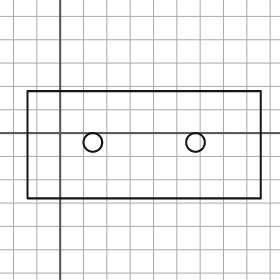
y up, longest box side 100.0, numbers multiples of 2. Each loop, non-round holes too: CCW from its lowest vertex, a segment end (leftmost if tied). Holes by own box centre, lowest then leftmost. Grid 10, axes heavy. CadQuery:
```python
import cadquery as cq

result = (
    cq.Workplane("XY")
    .moveTo(-14.0, -28.0)
    .lineTo(86.0, -28.0)
    .lineTo(86.0, 18.0)
    .lineTo(-14.0, 18.0)
    .close()
    .moveTo(14.0, -4.0)
    .circle(4.0)
    .moveTo(58.0, -4.0)
    .circle(4.0)
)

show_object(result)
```